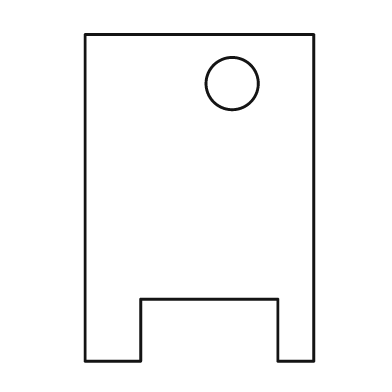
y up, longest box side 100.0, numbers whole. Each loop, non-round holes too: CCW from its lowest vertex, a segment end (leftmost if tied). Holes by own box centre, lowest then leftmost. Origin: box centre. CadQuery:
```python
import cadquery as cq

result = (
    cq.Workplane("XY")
    .moveTo(-35.0, -50.0)
    .lineTo(-18.0, -50.0)
    .lineTo(-18.0, -31.0)
    .lineTo(24.0, -31.0)
    .lineTo(24.0, -50.0)
    .lineTo(35.0, -50.0)
    .lineTo(35.0, 50.0)
    .lineTo(-35.0, 50.0)
    .close()
    .moveTo(10.0, 35.0)
    .circle(8.0)
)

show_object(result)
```